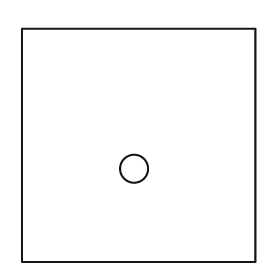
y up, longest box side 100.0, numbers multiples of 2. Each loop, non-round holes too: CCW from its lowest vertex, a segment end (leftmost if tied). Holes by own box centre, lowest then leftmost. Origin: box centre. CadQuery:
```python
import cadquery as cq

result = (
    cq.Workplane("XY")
    .moveTo(-50.0, -50.0)
    .lineTo(50.0, -50.0)
    .lineTo(50.0, 50.0)
    .lineTo(-50.0, 50.0)
    .close()
    .moveTo(-2.0, -10.0)
    .circle(6.0)
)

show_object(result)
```